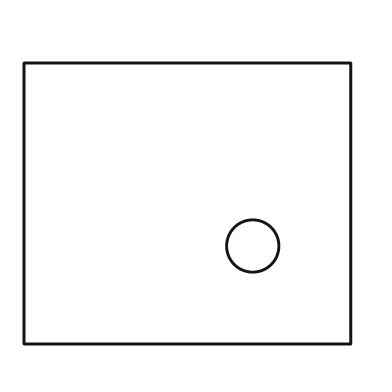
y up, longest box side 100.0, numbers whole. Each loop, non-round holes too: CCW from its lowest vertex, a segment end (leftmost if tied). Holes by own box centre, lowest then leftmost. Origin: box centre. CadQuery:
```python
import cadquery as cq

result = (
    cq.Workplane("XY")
    .moveTo(-50.0, -43.0)
    .lineTo(50.0, -43.0)
    .lineTo(50.0, 43.0)
    .lineTo(-50.0, 43.0)
    .close()
    .moveTo(20.0, -13.0)
    .circle(8.0)
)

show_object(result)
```